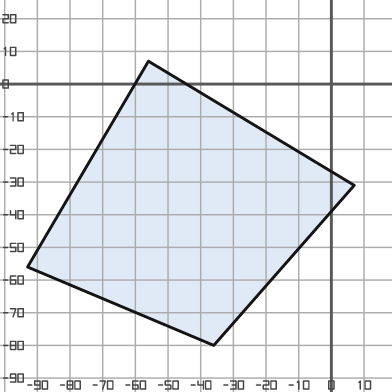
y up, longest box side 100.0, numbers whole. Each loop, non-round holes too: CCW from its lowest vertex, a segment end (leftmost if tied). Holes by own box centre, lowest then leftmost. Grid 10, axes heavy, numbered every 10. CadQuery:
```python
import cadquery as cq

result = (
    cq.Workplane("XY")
    .moveTo(-36.0, -80.0)
    .lineTo(7.0, -31.0)
    .lineTo(-56.0, 7.0)
    .lineTo(-93.0, -56.0)
    .close()
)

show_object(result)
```